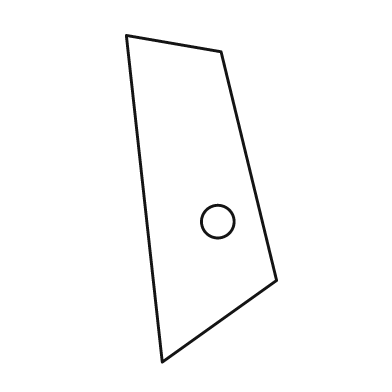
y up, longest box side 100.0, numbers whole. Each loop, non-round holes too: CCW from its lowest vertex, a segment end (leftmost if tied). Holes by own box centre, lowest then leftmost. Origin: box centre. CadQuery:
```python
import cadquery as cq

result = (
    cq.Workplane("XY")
    .moveTo(-12.0, -50.0)
    .lineTo(23.0, -25.0)
    .lineTo(6.0, 45.0)
    .lineTo(-23.0, 50.0)
    .close()
    .moveTo(5.0, -7.0)
    .circle(5.0)
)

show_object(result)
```